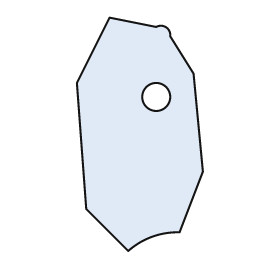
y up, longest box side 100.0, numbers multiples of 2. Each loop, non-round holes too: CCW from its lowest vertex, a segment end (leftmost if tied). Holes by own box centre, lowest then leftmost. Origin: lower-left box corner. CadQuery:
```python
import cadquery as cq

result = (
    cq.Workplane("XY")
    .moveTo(22.0, 0.0)
    .threePointArc((32.0, 6.0), (44.0, 8.0))
    .lineTo(54.0, 34.0)
    .lineTo(50.0, 76.0)
    .lineTo(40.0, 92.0)
    .threePointArc((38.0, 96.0), (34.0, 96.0))
    .lineTo(14.0, 100.0)
    .lineTo(0.0, 72.0)
    .lineTo(4.0, 18.0)
    .close()
    .moveTo(34.0, 66.0)
    .circle(6.0)
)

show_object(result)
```